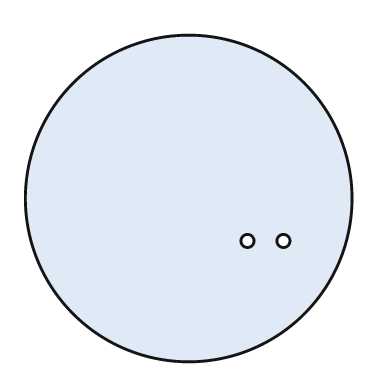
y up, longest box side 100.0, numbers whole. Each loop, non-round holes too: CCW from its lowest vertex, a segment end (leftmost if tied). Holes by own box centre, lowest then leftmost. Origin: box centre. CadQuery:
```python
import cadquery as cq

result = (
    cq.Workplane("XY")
    .moveTo(0.0, 0.0)
    .circle(50.0)
    .moveTo(18.0, -13.0)
    .circle(2.0)
    .moveTo(29.0, -13.0)
    .circle(2.0)
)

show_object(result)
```